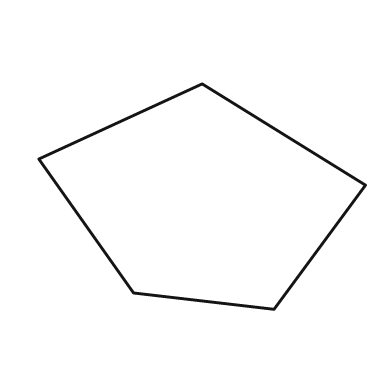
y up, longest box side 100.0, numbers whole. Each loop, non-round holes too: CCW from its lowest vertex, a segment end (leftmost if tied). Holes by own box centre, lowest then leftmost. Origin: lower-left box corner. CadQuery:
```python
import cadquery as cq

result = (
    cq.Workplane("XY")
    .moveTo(72.0, 0.0)
    .lineTo(100.0, 38.0)
    .lineTo(50.0, 69.0)
    .lineTo(0.0, 46.0)
    .lineTo(29.0, 5.0)
    .close()
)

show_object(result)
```